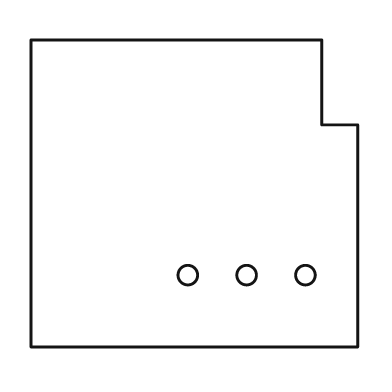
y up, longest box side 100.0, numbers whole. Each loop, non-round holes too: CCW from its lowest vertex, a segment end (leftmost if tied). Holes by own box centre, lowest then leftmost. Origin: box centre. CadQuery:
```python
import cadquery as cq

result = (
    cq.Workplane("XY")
    .moveTo(-50.0, -47.0)
    .lineTo(50.0, -47.0)
    .lineTo(50.0, 21.0)
    .lineTo(39.0, 21.0)
    .lineTo(39.0, 47.0)
    .lineTo(-50.0, 47.0)
    .close()
    .moveTo(-2.0, -25.0)
    .circle(3.0)
    .moveTo(16.0, -25.0)
    .circle(3.0)
    .moveTo(34.0, -25.0)
    .circle(3.0)
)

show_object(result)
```